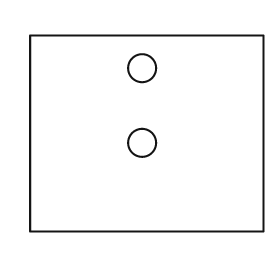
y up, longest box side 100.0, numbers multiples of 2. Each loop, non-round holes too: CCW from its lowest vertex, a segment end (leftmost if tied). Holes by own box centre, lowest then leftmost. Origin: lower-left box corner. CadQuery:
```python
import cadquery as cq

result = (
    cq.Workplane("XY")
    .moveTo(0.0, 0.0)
    .lineTo(100.0, 0.0)
    .lineTo(100.0, 84.0)
    .lineTo(0.0, 84.0)
    .close()
    .moveTo(48.0, 38.0)
    .circle(6.0)
    .moveTo(48.0, 70.0)
    .circle(6.0)
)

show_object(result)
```